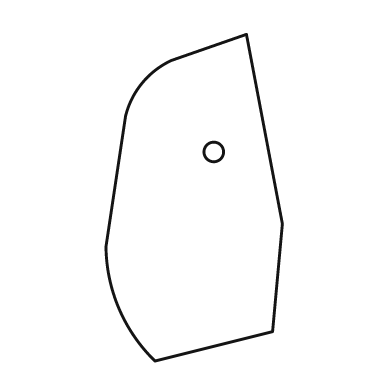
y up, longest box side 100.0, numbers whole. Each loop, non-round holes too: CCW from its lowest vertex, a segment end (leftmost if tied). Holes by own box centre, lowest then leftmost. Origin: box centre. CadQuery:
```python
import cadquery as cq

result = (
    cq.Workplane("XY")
    .moveTo(-12.0, -50.0)
    .lineTo(24.0, -41.0)
    .lineTo(27.0, -8.0)
    .lineTo(16.0, 50.0)
    .lineTo(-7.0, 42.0)
    .threePointArc((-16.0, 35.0), (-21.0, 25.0))
    .lineTo(-27.0, -15.0)
    .threePointArc((-23.0, -34.0), (-12.0, -50.0))
    .close()
    .moveTo(6.0, 14.0)
    .circle(3.0)
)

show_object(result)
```